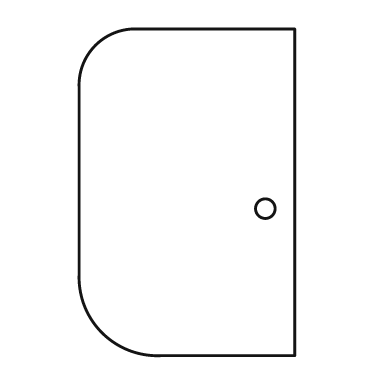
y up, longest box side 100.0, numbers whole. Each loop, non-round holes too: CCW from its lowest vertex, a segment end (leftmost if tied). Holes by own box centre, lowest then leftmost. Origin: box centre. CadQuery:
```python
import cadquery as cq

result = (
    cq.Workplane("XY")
    .moveTo(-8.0, -50.0)
    .lineTo(33.0, -50.0)
    .lineTo(33.0, 50.0)
    .lineTo(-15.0, 50.0)
    .threePointArc((-28.0, 45.0), (-33.0, 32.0))
    .lineTo(-33.0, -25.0)
    .threePointArc((-26.0, -43.0), (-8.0, -50.0))
    .close()
    .moveTo(24.0, -5.0)
    .circle(3.0)
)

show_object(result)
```